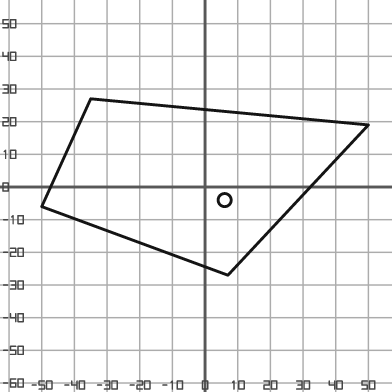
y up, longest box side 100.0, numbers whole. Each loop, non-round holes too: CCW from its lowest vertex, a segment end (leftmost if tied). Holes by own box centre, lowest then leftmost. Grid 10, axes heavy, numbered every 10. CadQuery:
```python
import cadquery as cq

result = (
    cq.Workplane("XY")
    .moveTo(7.0, -27.0)
    .lineTo(50.0, 19.0)
    .lineTo(-35.0, 27.0)
    .lineTo(-50.0, -6.0)
    .close()
    .moveTo(6.0, -4.0)
    .circle(2.0)
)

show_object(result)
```